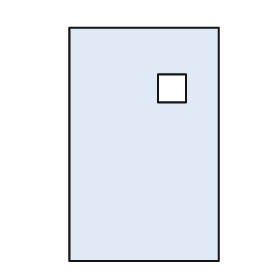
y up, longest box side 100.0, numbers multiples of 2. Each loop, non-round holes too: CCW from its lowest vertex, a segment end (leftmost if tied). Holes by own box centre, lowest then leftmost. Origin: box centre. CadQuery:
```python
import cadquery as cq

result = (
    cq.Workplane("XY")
    .moveTo(-32.0, -50.0)
    .lineTo(32.0, -50.0)
    .lineTo(32.0, 50.0)
    .lineTo(-32.0, 50.0)
    .close()
    .moveTo(6.0, 18.0)
    .lineTo(18.0, 18.0)
    .lineTo(18.0, 30.0)
    .lineTo(6.0, 30.0)
    .close()
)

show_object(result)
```